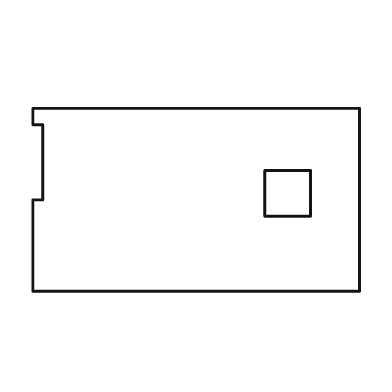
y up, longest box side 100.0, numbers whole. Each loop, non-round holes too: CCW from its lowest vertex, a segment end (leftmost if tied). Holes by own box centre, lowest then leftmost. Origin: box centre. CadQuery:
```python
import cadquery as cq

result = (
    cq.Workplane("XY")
    .moveTo(-50.0, -28.0)
    .lineTo(50.0, -28.0)
    .lineTo(50.0, 28.0)
    .lineTo(-50.0, 28.0)
    .lineTo(-50.0, 23.0)
    .lineTo(-47.0, 23.0)
    .lineTo(-47.0, 0.0)
    .lineTo(-50.0, 0.0)
    .close()
    .moveTo(21.0, -5.0)
    .lineTo(35.0, -5.0)
    .lineTo(35.0, 9.0)
    .lineTo(21.0, 9.0)
    .close()
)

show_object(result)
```